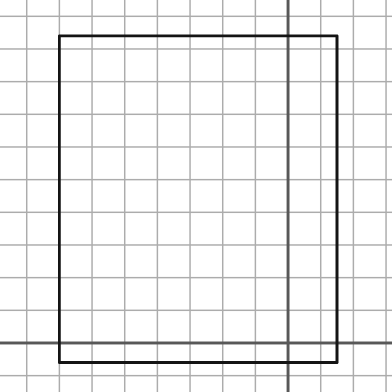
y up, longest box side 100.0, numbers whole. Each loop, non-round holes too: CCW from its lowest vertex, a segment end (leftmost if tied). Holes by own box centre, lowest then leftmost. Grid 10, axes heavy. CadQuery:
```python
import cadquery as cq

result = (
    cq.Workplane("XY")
    .moveTo(-70.0, -6.0)
    .lineTo(15.0, -6.0)
    .lineTo(15.0, 94.0)
    .lineTo(-70.0, 94.0)
    .close()
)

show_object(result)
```